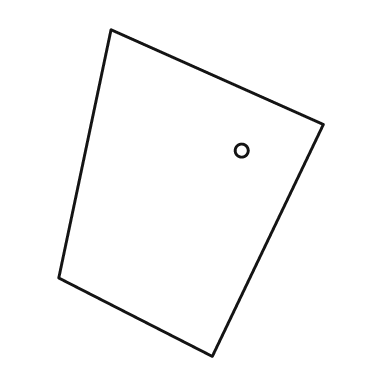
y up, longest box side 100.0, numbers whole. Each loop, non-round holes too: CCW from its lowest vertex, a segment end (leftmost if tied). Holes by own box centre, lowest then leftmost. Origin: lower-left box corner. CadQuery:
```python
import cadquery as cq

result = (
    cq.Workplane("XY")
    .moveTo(47.0, 0.0)
    .lineTo(81.0, 71.0)
    .lineTo(16.0, 100.0)
    .lineTo(0.0, 24.0)
    .close()
    .moveTo(56.0, 63.0)
    .circle(2.0)
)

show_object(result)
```